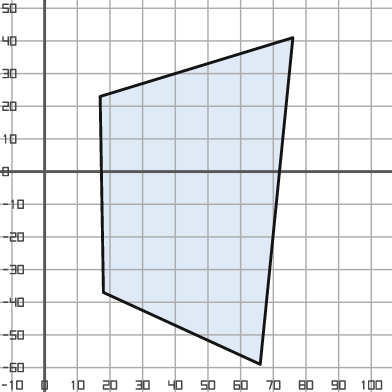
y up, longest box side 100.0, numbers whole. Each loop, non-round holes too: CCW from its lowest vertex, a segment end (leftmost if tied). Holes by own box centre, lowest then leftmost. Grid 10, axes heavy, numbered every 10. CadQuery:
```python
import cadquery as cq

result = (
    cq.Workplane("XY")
    .moveTo(66.0, -59.0)
    .lineTo(76.0, 41.0)
    .lineTo(17.0, 23.0)
    .lineTo(18.0, -37.0)
    .close()
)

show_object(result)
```